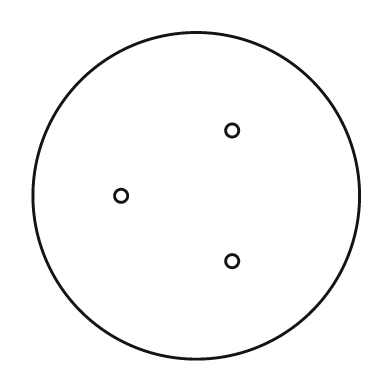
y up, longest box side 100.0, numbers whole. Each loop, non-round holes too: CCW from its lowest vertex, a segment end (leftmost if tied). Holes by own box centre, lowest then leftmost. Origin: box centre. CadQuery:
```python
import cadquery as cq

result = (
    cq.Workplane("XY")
    .moveTo(0.0, 0.0)
    .circle(50.0)
    .moveTo(11.0, -20.0)
    .circle(2.0)
    .moveTo(-23.0, 0.0)
    .circle(2.0)
    .moveTo(11.0, 20.0)
    .circle(2.0)
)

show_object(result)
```